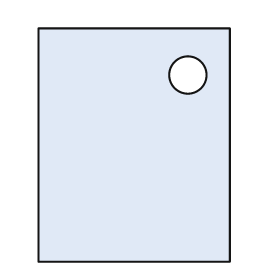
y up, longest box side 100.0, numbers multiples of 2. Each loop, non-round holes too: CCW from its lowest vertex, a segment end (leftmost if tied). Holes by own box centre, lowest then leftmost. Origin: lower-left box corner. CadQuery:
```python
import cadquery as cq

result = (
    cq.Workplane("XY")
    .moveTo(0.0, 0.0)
    .lineTo(82.0, 0.0)
    .lineTo(82.0, 100.0)
    .lineTo(0.0, 100.0)
    .close()
    .moveTo(64.0, 80.0)
    .circle(8.0)
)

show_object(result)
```